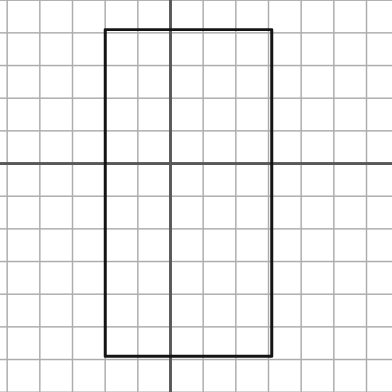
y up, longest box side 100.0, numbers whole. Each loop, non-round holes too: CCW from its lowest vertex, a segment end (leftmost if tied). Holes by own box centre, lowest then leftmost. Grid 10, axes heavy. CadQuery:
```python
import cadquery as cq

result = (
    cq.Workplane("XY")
    .moveTo(-20.0, -59.0)
    .lineTo(31.0, -59.0)
    .lineTo(31.0, 41.0)
    .lineTo(-20.0, 41.0)
    .close()
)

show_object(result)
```